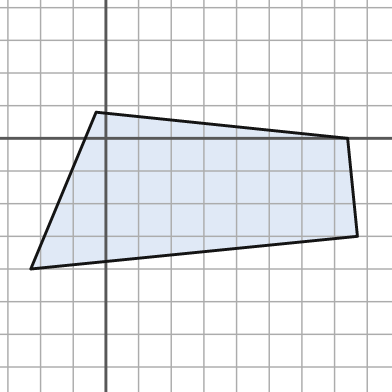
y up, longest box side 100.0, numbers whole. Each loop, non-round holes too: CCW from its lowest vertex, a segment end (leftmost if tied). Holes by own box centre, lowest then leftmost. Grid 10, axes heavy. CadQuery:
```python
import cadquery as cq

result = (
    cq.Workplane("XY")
    .moveTo(-23.0, -40.0)
    .lineTo(77.0, -30.0)
    .lineTo(74.0, 0.0)
    .lineTo(-3.0, 8.0)
    .close()
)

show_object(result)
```